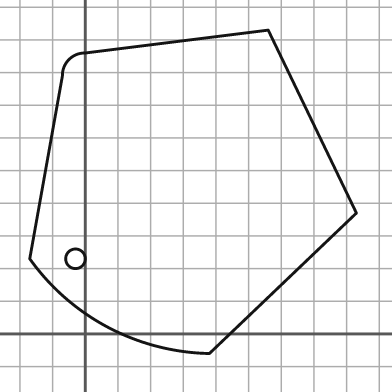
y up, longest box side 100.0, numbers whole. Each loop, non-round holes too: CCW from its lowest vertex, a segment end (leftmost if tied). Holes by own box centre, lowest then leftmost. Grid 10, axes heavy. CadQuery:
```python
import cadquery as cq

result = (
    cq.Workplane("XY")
    .moveTo(38.0, -6.0)
    .lineTo(83.0, 37.0)
    .lineTo(56.0, 93.0)
    .lineTo(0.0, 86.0)
    .threePointArc((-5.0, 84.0), (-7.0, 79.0))
    .lineTo(-17.0, 23.0)
    .threePointArc((7.0, 2.0), (38.0, -6.0))
    .close()
    .moveTo(-3.0, 23.0)
    .circle(3.0)
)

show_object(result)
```